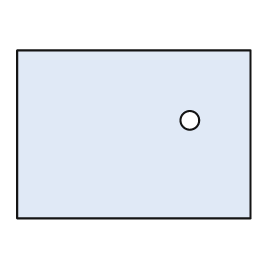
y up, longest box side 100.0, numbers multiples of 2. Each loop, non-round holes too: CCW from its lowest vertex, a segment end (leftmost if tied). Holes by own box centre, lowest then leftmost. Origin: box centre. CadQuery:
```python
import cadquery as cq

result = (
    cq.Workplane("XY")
    .moveTo(-50.0, -36.0)
    .lineTo(50.0, -36.0)
    .lineTo(50.0, 36.0)
    .lineTo(-50.0, 36.0)
    .close()
    .moveTo(24.0, 6.0)
    .circle(4.0)
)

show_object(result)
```